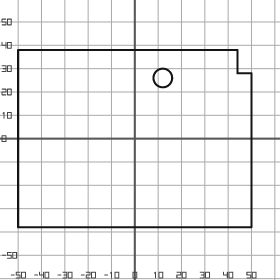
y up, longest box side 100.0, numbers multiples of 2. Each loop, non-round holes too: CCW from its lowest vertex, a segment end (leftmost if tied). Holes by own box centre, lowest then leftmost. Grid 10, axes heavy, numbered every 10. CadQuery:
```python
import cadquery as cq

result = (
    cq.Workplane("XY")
    .moveTo(-50.0, -38.0)
    .lineTo(50.0, -38.0)
    .lineTo(50.0, 28.0)
    .lineTo(44.0, 28.0)
    .lineTo(44.0, 38.0)
    .lineTo(-50.0, 38.0)
    .close()
    .moveTo(12.0, 26.0)
    .circle(4.0)
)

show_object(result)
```